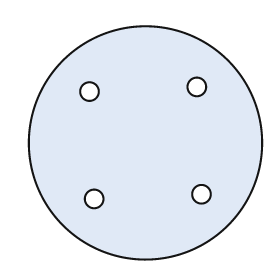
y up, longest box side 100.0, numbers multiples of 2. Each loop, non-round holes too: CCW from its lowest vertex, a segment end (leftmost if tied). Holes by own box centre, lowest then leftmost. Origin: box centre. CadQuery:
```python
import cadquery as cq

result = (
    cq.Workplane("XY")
    .moveTo(0.0, 0.0)
    .circle(50.0)
    .moveTo(-22.0, -24.0)
    .circle(4.0)
    .moveTo(24.0, -22.0)
    .circle(4.0)
    .moveTo(-24.0, 22.0)
    .circle(4.0)
    .moveTo(22.0, 24.0)
    .circle(4.0)
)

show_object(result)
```